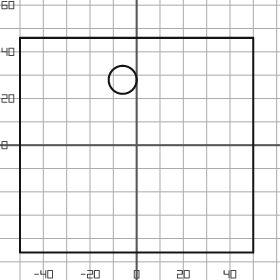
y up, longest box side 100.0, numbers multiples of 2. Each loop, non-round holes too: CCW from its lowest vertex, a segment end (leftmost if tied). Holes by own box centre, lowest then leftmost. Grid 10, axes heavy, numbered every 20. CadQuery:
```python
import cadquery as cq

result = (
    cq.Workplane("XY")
    .moveTo(-50.0, -46.0)
    .lineTo(50.0, -46.0)
    .lineTo(50.0, 46.0)
    .lineTo(-50.0, 46.0)
    .close()
    .moveTo(-6.0, 28.0)
    .circle(6.0)
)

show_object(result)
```